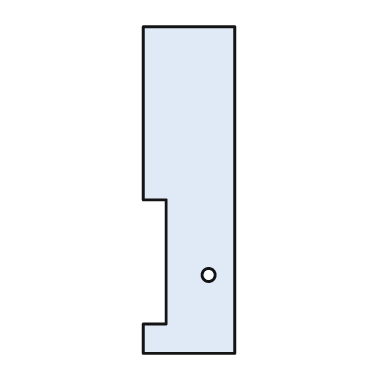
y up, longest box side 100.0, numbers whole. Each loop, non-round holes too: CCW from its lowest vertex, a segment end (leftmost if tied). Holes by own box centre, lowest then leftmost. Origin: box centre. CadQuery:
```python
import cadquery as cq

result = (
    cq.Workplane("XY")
    .moveTo(-14.0, -50.0)
    .lineTo(14.0, -50.0)
    .lineTo(14.0, 50.0)
    .lineTo(-14.0, 50.0)
    .lineTo(-14.0, -3.0)
    .lineTo(-7.0, -3.0)
    .lineTo(-7.0, -41.0)
    .lineTo(-14.0, -41.0)
    .close()
    .moveTo(6.0, -26.0)
    .circle(2.0)
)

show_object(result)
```